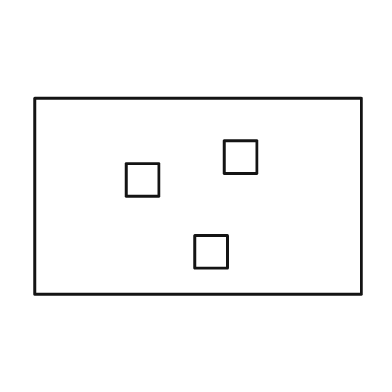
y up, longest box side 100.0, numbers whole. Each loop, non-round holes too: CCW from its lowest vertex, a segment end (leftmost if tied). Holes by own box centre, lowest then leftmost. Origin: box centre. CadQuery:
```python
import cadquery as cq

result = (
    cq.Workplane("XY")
    .moveTo(-50.0, -30.0)
    .lineTo(50.0, -30.0)
    .lineTo(50.0, 30.0)
    .lineTo(-50.0, 30.0)
    .close()
    .moveTo(-1.0, -22.0)
    .lineTo(9.0, -22.0)
    .lineTo(9.0, -12.0)
    .lineTo(-1.0, -12.0)
    .close()
    .moveTo(-22.0, 0.0)
    .lineTo(-12.0, 0.0)
    .lineTo(-12.0, 10.0)
    .lineTo(-22.0, 10.0)
    .close()
    .moveTo(8.0, 7.0)
    .lineTo(18.0, 7.0)
    .lineTo(18.0, 17.0)
    .lineTo(8.0, 17.0)
    .close()
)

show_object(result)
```